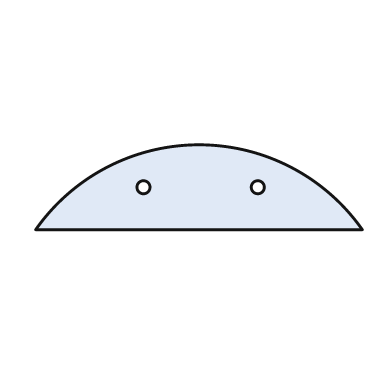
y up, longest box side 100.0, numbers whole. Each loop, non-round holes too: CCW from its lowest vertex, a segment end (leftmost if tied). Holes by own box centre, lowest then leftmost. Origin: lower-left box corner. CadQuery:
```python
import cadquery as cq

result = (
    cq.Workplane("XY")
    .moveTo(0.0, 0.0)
    .lineTo(100.0, 0.0)
    .threePointArc((50.0, 26.0), (0.0, 0.0))
    .close()
    .moveTo(33.0, 13.0)
    .circle(2.0)
    .moveTo(68.0, 13.0)
    .circle(2.0)
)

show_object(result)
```